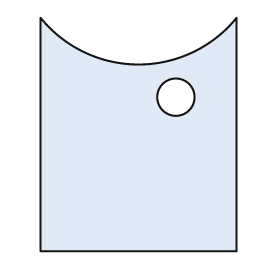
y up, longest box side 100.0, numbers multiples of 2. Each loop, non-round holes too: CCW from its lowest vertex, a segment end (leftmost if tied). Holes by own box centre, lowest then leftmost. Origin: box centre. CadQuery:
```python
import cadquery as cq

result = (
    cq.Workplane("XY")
    .moveTo(-42.0, -50.0)
    .lineTo(42.0, -50.0)
    .lineTo(42.0, 50.0)
    .threePointArc((0.0, 30.0), (-42.0, 50.0))
    .close()
    .moveTo(16.0, 16.0)
    .circle(8.0)
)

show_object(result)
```